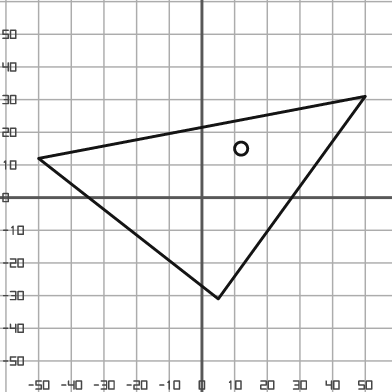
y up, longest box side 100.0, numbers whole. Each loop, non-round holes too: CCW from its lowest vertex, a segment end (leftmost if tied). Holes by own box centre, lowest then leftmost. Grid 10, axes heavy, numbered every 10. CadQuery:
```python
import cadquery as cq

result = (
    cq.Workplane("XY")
    .moveTo(5.0, -31.0)
    .lineTo(50.0, 31.0)
    .lineTo(-50.0, 12.0)
    .close()
    .moveTo(12.0, 15.0)
    .circle(2.0)
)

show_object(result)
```